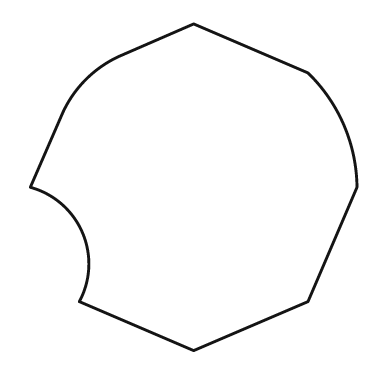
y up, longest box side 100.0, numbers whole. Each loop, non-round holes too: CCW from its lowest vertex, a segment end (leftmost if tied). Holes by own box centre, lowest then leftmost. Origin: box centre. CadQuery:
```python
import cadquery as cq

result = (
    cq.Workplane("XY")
    .moveTo(0.0, -50.0)
    .lineTo(35.0, -35.0)
    .lineTo(50.0, 0.0)
    .threePointArc((46.0, 19.0), (35.0, 35.0))
    .lineTo(0.0, 50.0)
    .lineTo(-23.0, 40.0)
    .threePointArc((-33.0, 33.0), (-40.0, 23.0))
    .lineTo(-50.0, 0.0)
    .threePointArc((-34.0, -14.0), (-35.0, -35.0))
    .close()
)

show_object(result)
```